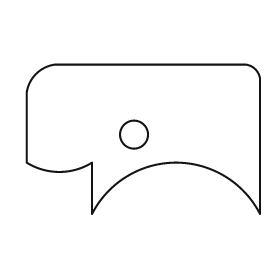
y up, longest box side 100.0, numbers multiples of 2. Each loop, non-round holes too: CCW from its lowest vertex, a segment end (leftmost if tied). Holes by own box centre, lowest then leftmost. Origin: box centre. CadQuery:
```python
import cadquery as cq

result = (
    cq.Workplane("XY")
    .moveTo(-22.0, -32.0)
    .threePointArc((14.0, -10.0), (50.0, -32.0))
    .lineTo(50.0, 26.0)
    .threePointArc((48.0, 30.0), (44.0, 32.0))
    .lineTo(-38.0, 32.0)
    .threePointArc((-46.0, 28.0), (-50.0, 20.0))
    .lineTo(-50.0, -10.0)
    .threePointArc((-36.0, -14.0), (-22.0, -10.0))
    .close()
    .moveTo(-4.0, 2.0)
    .circle(6.0)
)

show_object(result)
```